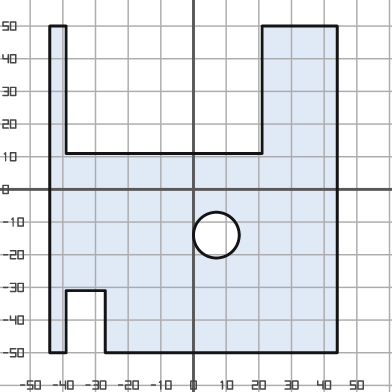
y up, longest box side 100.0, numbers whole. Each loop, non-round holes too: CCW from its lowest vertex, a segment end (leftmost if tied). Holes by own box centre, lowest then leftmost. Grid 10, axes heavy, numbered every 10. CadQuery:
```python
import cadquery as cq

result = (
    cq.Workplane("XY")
    .moveTo(-44.0, -50.0)
    .lineTo(-39.0, -50.0)
    .lineTo(-39.0, -31.0)
    .lineTo(-27.0, -31.0)
    .lineTo(-27.0, -50.0)
    .lineTo(44.0, -50.0)
    .lineTo(44.0, 50.0)
    .lineTo(21.0, 50.0)
    .lineTo(21.0, 11.0)
    .lineTo(-39.0, 11.0)
    .lineTo(-39.0, 50.0)
    .lineTo(-44.0, 50.0)
    .close()
    .moveTo(7.0, -14.0)
    .circle(7.0)
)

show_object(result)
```